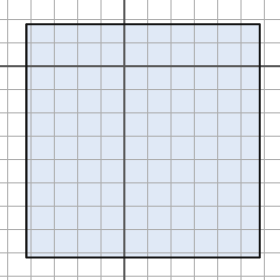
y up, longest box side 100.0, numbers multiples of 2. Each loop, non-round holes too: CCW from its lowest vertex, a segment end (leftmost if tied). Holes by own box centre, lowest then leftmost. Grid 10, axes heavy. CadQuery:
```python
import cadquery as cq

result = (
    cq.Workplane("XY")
    .moveTo(-42.0, -82.0)
    .lineTo(58.0, -82.0)
    .lineTo(58.0, 18.0)
    .lineTo(-42.0, 18.0)
    .close()
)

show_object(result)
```